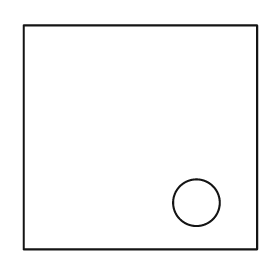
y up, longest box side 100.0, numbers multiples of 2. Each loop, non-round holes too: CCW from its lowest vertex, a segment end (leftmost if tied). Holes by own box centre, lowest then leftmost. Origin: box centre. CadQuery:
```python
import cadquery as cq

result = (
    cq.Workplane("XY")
    .moveTo(-50.0, -48.0)
    .lineTo(50.0, -48.0)
    .lineTo(50.0, 48.0)
    .lineTo(-50.0, 48.0)
    .close()
    .moveTo(24.0, -28.0)
    .circle(10.0)
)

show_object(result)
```